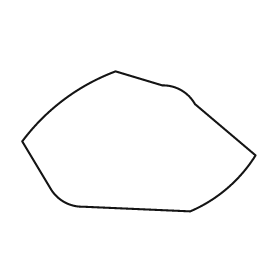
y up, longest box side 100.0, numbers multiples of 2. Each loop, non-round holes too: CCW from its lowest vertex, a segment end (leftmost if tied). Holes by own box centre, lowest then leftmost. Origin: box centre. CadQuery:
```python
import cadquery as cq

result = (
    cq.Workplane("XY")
    .moveTo(22.0, -30.0)
    .threePointArc((38.0, -20.0), (50.0, -6.0))
    .lineTo(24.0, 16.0)
    .threePointArc((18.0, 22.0), (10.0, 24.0))
    .lineTo(-10.0, 30.0)
    .threePointArc((-32.0, 18.0), (-50.0, 0.0))
    .lineTo(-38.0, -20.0)
    .threePointArc((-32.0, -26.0), (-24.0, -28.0))
    .close()
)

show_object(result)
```